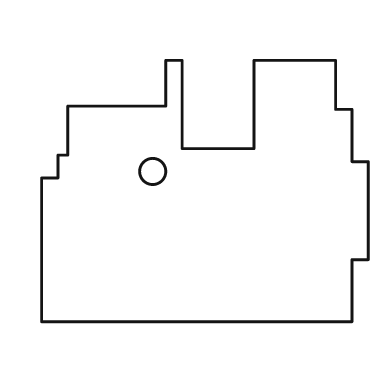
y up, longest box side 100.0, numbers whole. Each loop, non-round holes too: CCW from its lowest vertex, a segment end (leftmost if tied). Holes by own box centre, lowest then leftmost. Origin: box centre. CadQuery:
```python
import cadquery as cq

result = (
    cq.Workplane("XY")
    .moveTo(-50.0, -40.0)
    .lineTo(45.0, -40.0)
    .lineTo(45.0, -21.0)
    .lineTo(50.0, -21.0)
    .lineTo(50.0, 9.0)
    .lineTo(45.0, 9.0)
    .lineTo(45.0, 25.0)
    .lineTo(40.0, 25.0)
    .lineTo(40.0, 40.0)
    .lineTo(15.0, 40.0)
    .lineTo(15.0, 13.0)
    .lineTo(-7.0, 13.0)
    .lineTo(-7.0, 40.0)
    .lineTo(-12.0, 40.0)
    .lineTo(-12.0, 26.0)
    .lineTo(-42.0, 26.0)
    .lineTo(-42.0, 11.0)
    .lineTo(-45.0, 11.0)
    .lineTo(-45.0, 4.0)
    .lineTo(-50.0, 4.0)
    .close()
    .moveTo(-16.0, 6.0)
    .circle(4.0)
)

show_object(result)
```